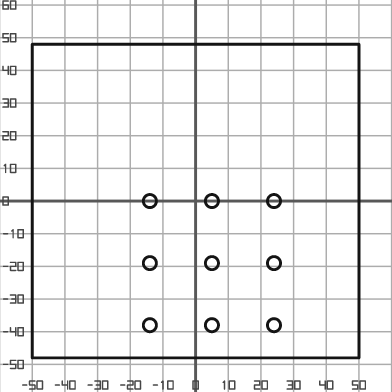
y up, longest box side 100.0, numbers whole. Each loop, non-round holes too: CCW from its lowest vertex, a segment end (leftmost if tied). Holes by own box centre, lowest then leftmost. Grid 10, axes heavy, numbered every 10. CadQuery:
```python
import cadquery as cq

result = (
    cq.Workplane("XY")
    .moveTo(-50.0, -48.0)
    .lineTo(50.0, -48.0)
    .lineTo(50.0, 48.0)
    .lineTo(-50.0, 48.0)
    .close()
    .moveTo(-14.0, -38.0)
    .circle(2.0)
    .moveTo(5.0, -38.0)
    .circle(2.0)
    .moveTo(24.0, -38.0)
    .circle(2.0)
    .moveTo(-14.0, -19.0)
    .circle(2.0)
    .moveTo(5.0, -19.0)
    .circle(2.0)
    .moveTo(24.0, -19.0)
    .circle(2.0)
    .moveTo(-14.0, 0.0)
    .circle(2.0)
    .moveTo(5.0, 0.0)
    .circle(2.0)
    .moveTo(24.0, 0.0)
    .circle(2.0)
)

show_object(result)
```